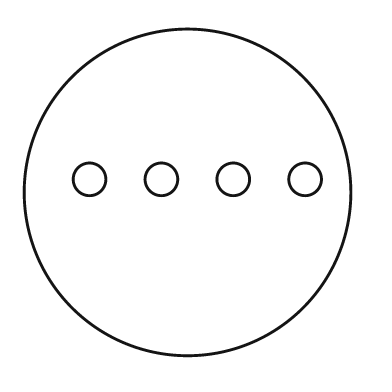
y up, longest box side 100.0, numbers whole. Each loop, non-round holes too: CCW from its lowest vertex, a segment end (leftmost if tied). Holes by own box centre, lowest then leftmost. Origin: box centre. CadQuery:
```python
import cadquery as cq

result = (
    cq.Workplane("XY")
    .moveTo(0.0, 0.0)
    .circle(50.0)
    .moveTo(-30.0, 4.0)
    .circle(5.0)
    .moveTo(-8.0, 4.0)
    .circle(5.0)
    .moveTo(14.0, 4.0)
    .circle(5.0)
    .moveTo(36.0, 4.0)
    .circle(5.0)
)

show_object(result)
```